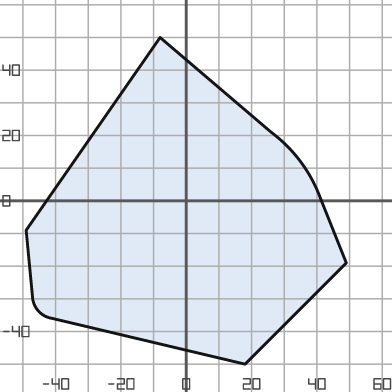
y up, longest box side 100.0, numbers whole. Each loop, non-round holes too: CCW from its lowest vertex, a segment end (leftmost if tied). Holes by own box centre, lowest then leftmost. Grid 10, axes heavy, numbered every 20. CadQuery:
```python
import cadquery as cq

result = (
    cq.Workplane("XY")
    .moveTo(18.0, -50.0)
    .lineTo(49.0, -19.0)
    .lineTo(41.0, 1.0)
    .threePointArc((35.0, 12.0), (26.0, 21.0))
    .lineTo(-8.0, 50.0)
    .lineTo(-49.0, -9.0)
    .lineTo(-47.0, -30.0)
    .threePointArc((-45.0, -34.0), (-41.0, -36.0))
    .close()
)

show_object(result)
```